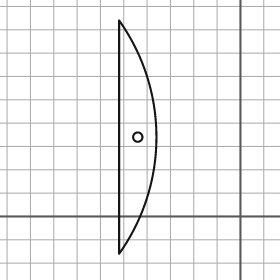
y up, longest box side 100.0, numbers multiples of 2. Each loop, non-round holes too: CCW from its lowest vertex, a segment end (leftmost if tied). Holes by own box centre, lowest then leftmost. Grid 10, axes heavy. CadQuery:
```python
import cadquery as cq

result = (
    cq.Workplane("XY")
    .moveTo(-52.0, -16.0)
    .threePointArc((-36.0, 34.0), (-52.0, 84.0))
    .close()
    .moveTo(-44.0, 34.0)
    .circle(2.0)
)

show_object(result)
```